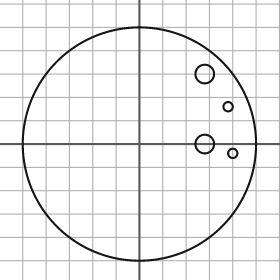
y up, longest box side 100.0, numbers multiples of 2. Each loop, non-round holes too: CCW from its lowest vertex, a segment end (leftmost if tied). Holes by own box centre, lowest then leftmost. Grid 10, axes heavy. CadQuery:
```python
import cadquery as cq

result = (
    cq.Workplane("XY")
    .moveTo(0.0, 0.0)
    .circle(50.0)
    .moveTo(40.0, -4.0)
    .circle(2.0)
    .moveTo(28.0, 0.0)
    .circle(4.0)
    .moveTo(38.0, 16.0)
    .circle(2.0)
    .moveTo(28.0, 30.0)
    .circle(4.0)
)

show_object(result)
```